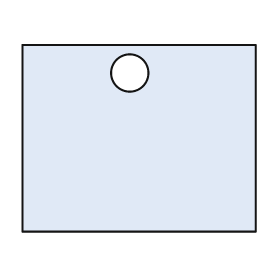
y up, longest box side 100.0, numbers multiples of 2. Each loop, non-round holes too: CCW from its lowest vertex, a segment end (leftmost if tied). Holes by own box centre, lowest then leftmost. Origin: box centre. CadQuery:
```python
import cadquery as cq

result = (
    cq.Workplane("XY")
    .moveTo(-50.0, -40.0)
    .lineTo(50.0, -40.0)
    .lineTo(50.0, 40.0)
    .lineTo(-50.0, 40.0)
    .close()
    .moveTo(-4.0, 28.0)
    .circle(8.0)
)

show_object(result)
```